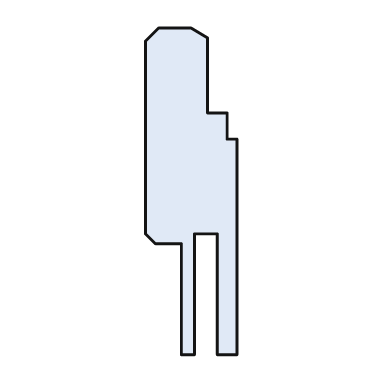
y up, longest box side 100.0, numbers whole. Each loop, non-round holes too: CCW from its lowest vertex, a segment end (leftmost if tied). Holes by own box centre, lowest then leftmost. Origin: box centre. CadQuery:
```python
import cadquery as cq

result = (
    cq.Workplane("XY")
    .moveTo(-3.0, -50.0)
    .lineTo(1.0, -50.0)
    .lineTo(1.0, -13.0)
    .lineTo(8.0, -13.0)
    .lineTo(8.0, -50.0)
    .lineTo(14.0, -50.0)
    .lineTo(14.0, 16.0)
    .lineTo(11.0, 16.0)
    .lineTo(11.0, 24.0)
    .lineTo(5.0, 24.0)
    .lineTo(5.0, 47.0)
    .lineTo(0.0, 50.0)
    .lineTo(-10.0, 50.0)
    .lineTo(-14.0, 46.0)
    .lineTo(-14.0, -13.0)
    .lineTo(-11.0, -16.0)
    .lineTo(-3.0, -16.0)
    .close()
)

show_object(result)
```